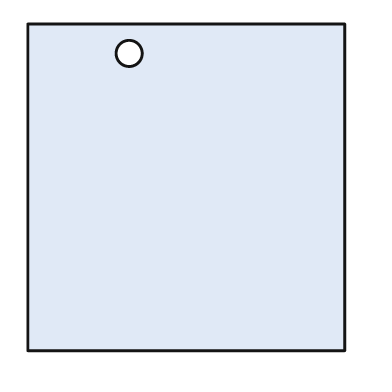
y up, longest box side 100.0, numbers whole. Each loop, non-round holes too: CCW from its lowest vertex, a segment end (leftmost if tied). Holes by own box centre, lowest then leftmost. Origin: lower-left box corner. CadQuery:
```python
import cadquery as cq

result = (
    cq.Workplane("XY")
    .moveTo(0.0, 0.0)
    .lineTo(97.0, 0.0)
    .lineTo(97.0, 100.0)
    .lineTo(0.0, 100.0)
    .close()
    .moveTo(31.0, 91.0)
    .circle(4.0)
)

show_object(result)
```